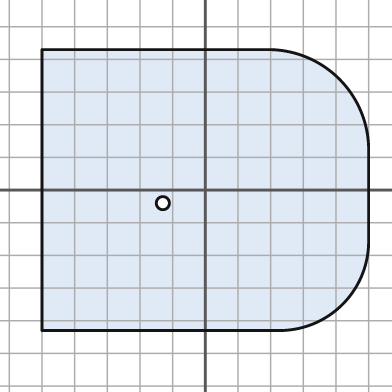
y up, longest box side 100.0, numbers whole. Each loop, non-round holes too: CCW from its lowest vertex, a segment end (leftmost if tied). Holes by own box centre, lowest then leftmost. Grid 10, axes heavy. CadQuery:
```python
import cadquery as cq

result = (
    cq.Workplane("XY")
    .moveTo(-50.0, -43.0)
    .lineTo(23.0, -43.0)
    .threePointArc((42.0, -35.0), (50.0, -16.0))
    .lineTo(50.0, 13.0)
    .threePointArc((41.0, 34.0), (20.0, 43.0))
    .lineTo(-50.0, 43.0)
    .close()
    .moveTo(-13.0, -4.0)
    .circle(2.0)
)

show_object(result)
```